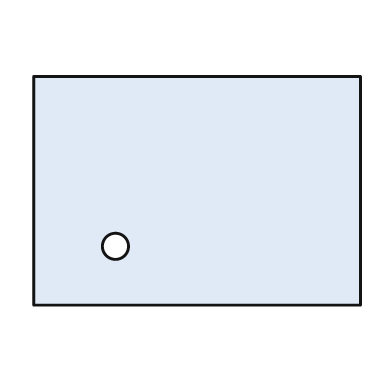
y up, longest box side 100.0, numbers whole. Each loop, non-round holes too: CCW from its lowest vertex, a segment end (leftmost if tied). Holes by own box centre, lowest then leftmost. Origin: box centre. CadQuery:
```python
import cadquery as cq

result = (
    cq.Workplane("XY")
    .moveTo(-50.0, -35.0)
    .lineTo(50.0, -35.0)
    .lineTo(50.0, 35.0)
    .lineTo(-50.0, 35.0)
    .close()
    .moveTo(-25.0, -17.0)
    .circle(4.0)
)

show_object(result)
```